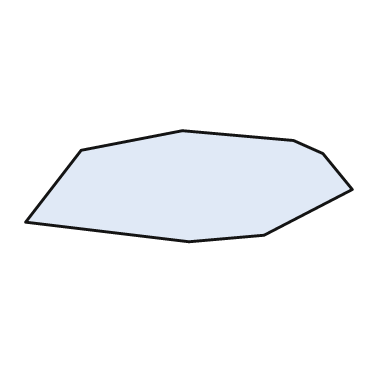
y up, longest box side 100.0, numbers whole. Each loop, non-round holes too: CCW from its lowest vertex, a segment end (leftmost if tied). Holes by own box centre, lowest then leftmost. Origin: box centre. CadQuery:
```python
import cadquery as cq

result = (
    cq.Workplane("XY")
    .moveTo(0.0, -17.0)
    .lineTo(23.0, -15.0)
    .lineTo(50.0, -1.0)
    .lineTo(41.0, 10.0)
    .lineTo(32.0, 14.0)
    .lineTo(-2.0, 17.0)
    .lineTo(-33.0, 11.0)
    .lineTo(-50.0, -11.0)
    .close()
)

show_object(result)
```